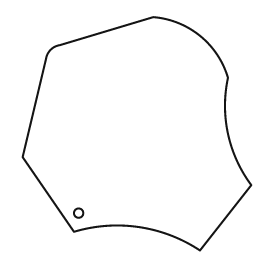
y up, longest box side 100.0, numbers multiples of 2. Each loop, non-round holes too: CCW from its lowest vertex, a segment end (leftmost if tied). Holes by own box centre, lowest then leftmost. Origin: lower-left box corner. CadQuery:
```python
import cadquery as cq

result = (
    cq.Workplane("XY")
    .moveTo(76.0, 0.0)
    .lineTo(98.0, 28.0)
    .threePointArc((88.0, 50.0), (88.0, 74.0))
    .threePointArc((76.0, 92.0), (56.0, 100.0))
    .lineTo(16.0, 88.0)
    .threePointArc((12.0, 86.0), (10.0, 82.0))
    .lineTo(0.0, 40.0)
    .lineTo(22.0, 8.0)
    .threePointArc((50.0, 10.0), (76.0, 0.0))
    .close()
    .moveTo(24.0, 16.0)
    .circle(2.0)
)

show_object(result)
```